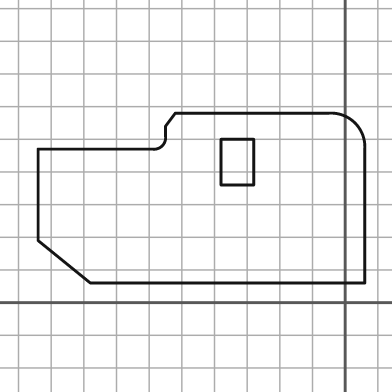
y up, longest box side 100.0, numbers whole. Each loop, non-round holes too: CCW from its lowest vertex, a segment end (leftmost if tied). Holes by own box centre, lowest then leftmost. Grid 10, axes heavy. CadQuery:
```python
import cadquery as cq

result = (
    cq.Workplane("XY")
    .moveTo(-78.0, 6.0)
    .lineTo(6.0, 6.0)
    .lineTo(6.0, 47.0)
    .threePointArc((3.0, 55.0), (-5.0, 58.0))
    .lineTo(-52.0, 58.0)
    .lineTo(-55.0, 54.0)
    .lineTo(-55.0, 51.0)
    .threePointArc((-56.0, 48.0), (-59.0, 47.0))
    .lineTo(-94.0, 47.0)
    .lineTo(-94.0, 19.0)
    .close()
    .moveTo(-38.0, 36.0)
    .lineTo(-28.0, 36.0)
    .lineTo(-28.0, 50.0)
    .lineTo(-38.0, 50.0)
    .close()
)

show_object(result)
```